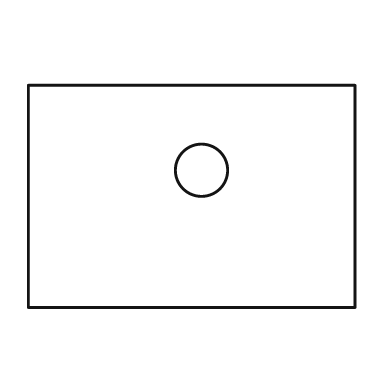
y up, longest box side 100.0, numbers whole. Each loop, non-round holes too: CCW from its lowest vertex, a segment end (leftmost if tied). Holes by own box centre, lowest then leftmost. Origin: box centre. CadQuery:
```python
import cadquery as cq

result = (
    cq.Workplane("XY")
    .moveTo(-50.0, -34.0)
    .lineTo(50.0, -34.0)
    .lineTo(50.0, 34.0)
    .lineTo(-50.0, 34.0)
    .close()
    .moveTo(3.0, 8.0)
    .circle(8.0)
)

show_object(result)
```